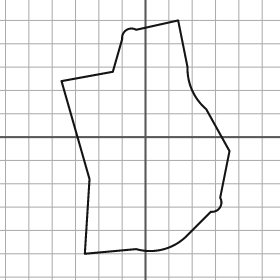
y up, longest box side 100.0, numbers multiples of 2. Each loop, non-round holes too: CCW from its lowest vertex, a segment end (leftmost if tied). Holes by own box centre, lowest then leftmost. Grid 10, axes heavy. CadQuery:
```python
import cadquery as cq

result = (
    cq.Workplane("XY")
    .moveTo(-26.0, -50.0)
    .lineTo(-4.0, -48.0)
    .threePointArc((8.0, -48.0), (18.0, -42.0))
    .lineTo(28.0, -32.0)
    .threePointArc((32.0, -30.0), (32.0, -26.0))
    .lineTo(36.0, -6.0)
    .lineTo(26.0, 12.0)
    .threePointArc((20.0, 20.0), (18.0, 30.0))
    .lineTo(14.0, 50.0)
    .lineTo(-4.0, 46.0)
    .threePointArc((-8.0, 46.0), (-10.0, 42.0))
    .lineTo(-14.0, 28.0)
    .lineTo(-36.0, 24.0)
    .lineTo(-24.0, -18.0)
    .close()
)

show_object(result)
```